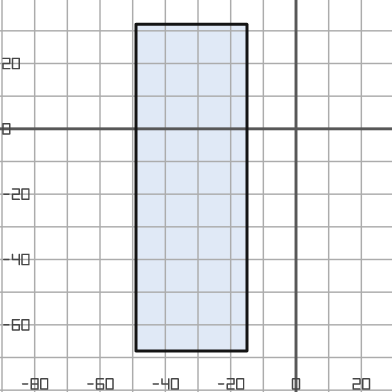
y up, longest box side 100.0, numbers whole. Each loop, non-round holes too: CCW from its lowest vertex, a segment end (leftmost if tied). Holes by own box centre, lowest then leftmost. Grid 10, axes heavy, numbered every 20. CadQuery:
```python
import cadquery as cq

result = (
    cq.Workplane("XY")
    .moveTo(-49.0, -68.0)
    .lineTo(-15.0, -68.0)
    .lineTo(-15.0, 32.0)
    .lineTo(-49.0, 32.0)
    .close()
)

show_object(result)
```